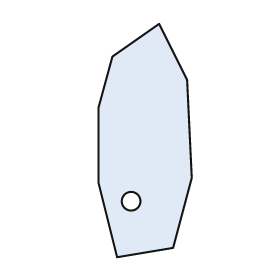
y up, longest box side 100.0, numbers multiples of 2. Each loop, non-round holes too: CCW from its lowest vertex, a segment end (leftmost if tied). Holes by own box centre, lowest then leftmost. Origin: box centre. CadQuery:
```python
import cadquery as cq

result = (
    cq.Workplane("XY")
    .moveTo(-12.0, -50.0)
    .lineTo(12.0, -46.0)
    .lineTo(20.0, -16.0)
    .lineTo(18.0, 26.0)
    .lineTo(6.0, 50.0)
    .lineTo(-14.0, 36.0)
    .lineTo(-20.0, 14.0)
    .lineTo(-20.0, -18.0)
    .close()
    .moveTo(-6.0, -26.0)
    .circle(4.0)
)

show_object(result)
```